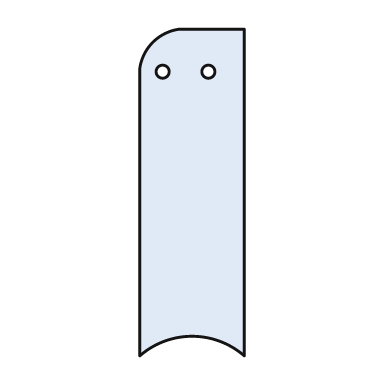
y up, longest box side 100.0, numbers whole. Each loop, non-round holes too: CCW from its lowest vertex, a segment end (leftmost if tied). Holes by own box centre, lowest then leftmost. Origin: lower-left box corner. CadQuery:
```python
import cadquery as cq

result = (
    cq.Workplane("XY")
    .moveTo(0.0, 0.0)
    .threePointArc((16.0, 6.0), (32.0, 0.0))
    .lineTo(32.0, 100.0)
    .lineTo(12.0, 100.0)
    .threePointArc((4.0, 96.0), (0.0, 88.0))
    .close()
    .moveTo(7.0, 87.0)
    .circle(2.0)
    .moveTo(21.0, 87.0)
    .circle(2.0)
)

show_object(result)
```